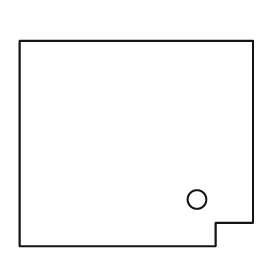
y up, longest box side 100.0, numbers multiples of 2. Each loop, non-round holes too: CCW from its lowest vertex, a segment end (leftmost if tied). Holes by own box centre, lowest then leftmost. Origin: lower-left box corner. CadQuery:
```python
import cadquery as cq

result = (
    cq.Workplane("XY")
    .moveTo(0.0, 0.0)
    .lineTo(84.0, 0.0)
    .lineTo(84.0, 10.0)
    .lineTo(100.0, 10.0)
    .lineTo(100.0, 88.0)
    .lineTo(0.0, 88.0)
    .close()
    .moveTo(76.0, 20.0)
    .circle(4.0)
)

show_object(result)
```